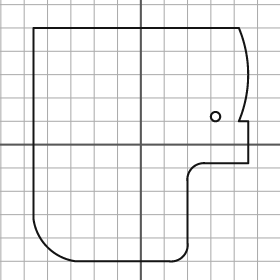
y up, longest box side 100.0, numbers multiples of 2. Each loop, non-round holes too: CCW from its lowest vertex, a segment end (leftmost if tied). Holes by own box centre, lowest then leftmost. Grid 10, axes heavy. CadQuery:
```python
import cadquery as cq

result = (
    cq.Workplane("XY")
    .moveTo(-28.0, -50.0)
    .lineTo(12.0, -50.0)
    .threePointArc((18.0, -48.0), (20.0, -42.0))
    .lineTo(20.0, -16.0)
    .threePointArc((22.0, -10.0), (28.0, -8.0))
    .lineTo(46.0, -8.0)
    .lineTo(46.0, 10.0)
    .lineTo(42.0, 10.0)
    .threePointArc((46.0, 30.0), (42.0, 50.0))
    .lineTo(-46.0, 50.0)
    .lineTo(-46.0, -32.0)
    .threePointArc((-40.0, -44.0), (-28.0, -50.0))
    .close()
    .moveTo(32.0, 12.0)
    .circle(2.0)
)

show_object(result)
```